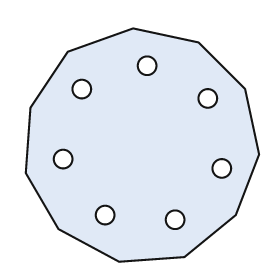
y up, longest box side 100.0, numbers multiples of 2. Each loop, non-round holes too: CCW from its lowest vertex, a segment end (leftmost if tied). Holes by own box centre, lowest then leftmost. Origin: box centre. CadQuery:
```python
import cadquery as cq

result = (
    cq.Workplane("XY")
    .moveTo(-10.0, -50.0)
    .lineTo(18.0, -48.0)
    .lineTo(40.0, -30.0)
    .lineTo(50.0, -4.0)
    .lineTo(44.0, 24.0)
    .lineTo(24.0, 44.0)
    .lineTo(-4.0, 50.0)
    .lineTo(-32.0, 40.0)
    .lineTo(-48.0, 16.0)
    .lineTo(-50.0, -12.0)
    .lineTo(-36.0, -36.0)
    .close()
    .moveTo(14.0, -32.0)
    .circle(4.0)
    .moveTo(-16.0, -30.0)
    .circle(4.0)
    .moveTo(34.0, -10.0)
    .circle(4.0)
    .moveTo(-34.0, -6.0)
    .circle(4.0)
    .moveTo(28.0, 20.0)
    .circle(4.0)
    .moveTo(-26.0, 24.0)
    .circle(4.0)
    .moveTo(2.0, 34.0)
    .circle(4.0)
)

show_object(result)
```